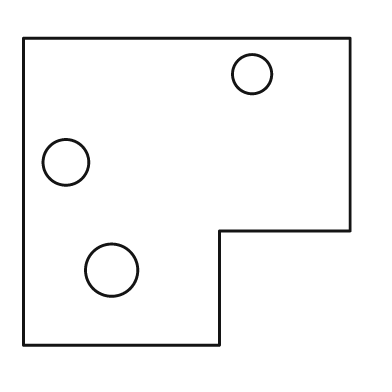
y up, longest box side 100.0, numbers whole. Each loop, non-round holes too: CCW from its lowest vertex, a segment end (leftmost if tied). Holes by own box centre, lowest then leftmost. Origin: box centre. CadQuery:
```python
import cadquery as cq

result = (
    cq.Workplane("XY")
    .moveTo(-50.0, -47.0)
    .lineTo(10.0, -47.0)
    .lineTo(10.0, -12.0)
    .lineTo(50.0, -12.0)
    .lineTo(50.0, 47.0)
    .lineTo(-50.0, 47.0)
    .close()
    .moveTo(-23.0, -24.0)
    .circle(8.0)
    .moveTo(-37.0, 9.0)
    .circle(7.0)
    .moveTo(20.0, 36.0)
    .circle(6.0)
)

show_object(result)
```